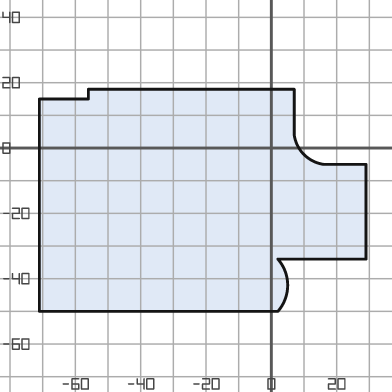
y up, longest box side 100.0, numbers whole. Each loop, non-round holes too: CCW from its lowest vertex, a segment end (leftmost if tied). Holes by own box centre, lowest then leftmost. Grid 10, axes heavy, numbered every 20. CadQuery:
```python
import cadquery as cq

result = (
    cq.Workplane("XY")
    .moveTo(-71.0, -50.0)
    .lineTo(2.0, -50.0)
    .threePointArc((5.0, -42.0), (2.0, -34.0))
    .lineTo(29.0, -34.0)
    .lineTo(29.0, -5.0)
    .lineTo(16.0, -5.0)
    .threePointArc((10.0, -2.0), (7.0, 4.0))
    .lineTo(7.0, 18.0)
    .lineTo(-56.0, 18.0)
    .lineTo(-56.0, 15.0)
    .lineTo(-71.0, 15.0)
    .close()
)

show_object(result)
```